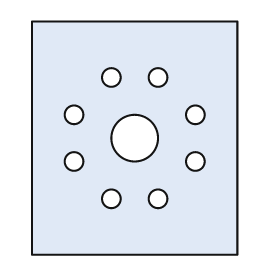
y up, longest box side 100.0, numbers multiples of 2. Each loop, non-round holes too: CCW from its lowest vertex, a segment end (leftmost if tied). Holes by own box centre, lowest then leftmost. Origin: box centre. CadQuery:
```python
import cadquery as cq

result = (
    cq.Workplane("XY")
    .moveTo(-44.0, -50.0)
    .lineTo(44.0, -50.0)
    .lineTo(44.0, 50.0)
    .lineTo(-44.0, 50.0)
    .close()
    .moveTo(-10.0, -26.0)
    .circle(4.0)
    .moveTo(10.0, -26.0)
    .circle(4.0)
    .moveTo(-26.0, -10.0)
    .circle(4.0)
    .moveTo(26.0, -10.0)
    .circle(4.0)
    .moveTo(0.0, 0.0)
    .circle(10.0)
    .moveTo(-26.0, 10.0)
    .circle(4.0)
    .moveTo(26.0, 10.0)
    .circle(4.0)
    .moveTo(-10.0, 26.0)
    .circle(4.0)
    .moveTo(10.0, 26.0)
    .circle(4.0)
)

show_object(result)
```